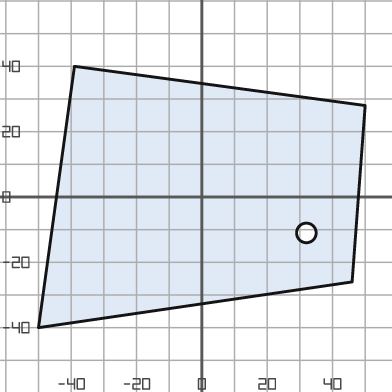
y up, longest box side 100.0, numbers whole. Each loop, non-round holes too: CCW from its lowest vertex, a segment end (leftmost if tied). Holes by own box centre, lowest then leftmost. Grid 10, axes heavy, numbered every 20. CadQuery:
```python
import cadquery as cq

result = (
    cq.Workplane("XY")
    .moveTo(-50.0, -40.0)
    .lineTo(46.0, -26.0)
    .lineTo(50.0, 28.0)
    .lineTo(-39.0, 40.0)
    .close()
    .moveTo(32.0, -11.0)
    .circle(3.0)
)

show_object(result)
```